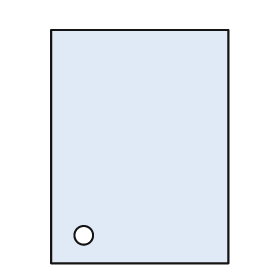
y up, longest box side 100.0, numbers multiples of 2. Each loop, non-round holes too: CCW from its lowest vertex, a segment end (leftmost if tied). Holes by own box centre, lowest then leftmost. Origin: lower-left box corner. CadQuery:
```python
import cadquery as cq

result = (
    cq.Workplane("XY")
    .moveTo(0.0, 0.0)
    .lineTo(76.0, 0.0)
    .lineTo(76.0, 100.0)
    .lineTo(0.0, 100.0)
    .close()
    .moveTo(14.0, 12.0)
    .circle(4.0)
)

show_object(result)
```